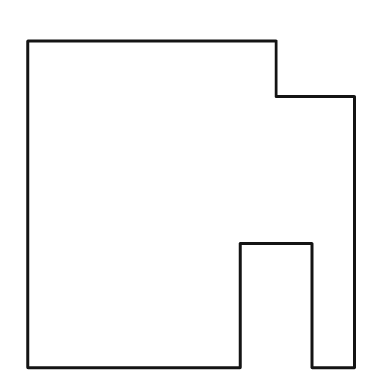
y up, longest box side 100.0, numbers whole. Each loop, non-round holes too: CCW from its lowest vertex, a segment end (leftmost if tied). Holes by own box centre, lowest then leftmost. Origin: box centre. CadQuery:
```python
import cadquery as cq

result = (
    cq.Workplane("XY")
    .moveTo(-50.0, -50.0)
    .lineTo(15.0, -50.0)
    .lineTo(15.0, -12.0)
    .lineTo(37.0, -12.0)
    .lineTo(37.0, -50.0)
    .lineTo(50.0, -50.0)
    .lineTo(50.0, 33.0)
    .lineTo(26.0, 33.0)
    .lineTo(26.0, 50.0)
    .lineTo(-50.0, 50.0)
    .close()
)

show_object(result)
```